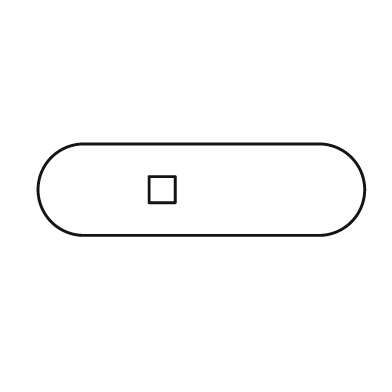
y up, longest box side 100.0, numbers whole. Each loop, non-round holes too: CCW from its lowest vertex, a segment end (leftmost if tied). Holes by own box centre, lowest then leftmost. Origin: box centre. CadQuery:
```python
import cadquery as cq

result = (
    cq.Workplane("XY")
    .moveTo(-36.0, -14.0)
    .lineTo(36.0, -14.0)
    .threePointArc((50.0, 0.0), (36.0, 14.0))
    .lineTo(-36.0, 14.0)
    .threePointArc((-50.0, 0.0), (-36.0, -14.0))
    .close()
    .moveTo(-16.0, -4.0)
    .lineTo(-8.0, -4.0)
    .lineTo(-8.0, 4.0)
    .lineTo(-16.0, 4.0)
    .close()
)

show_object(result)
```